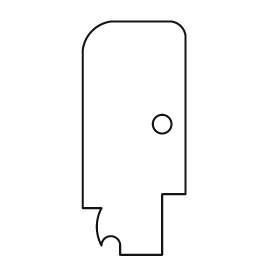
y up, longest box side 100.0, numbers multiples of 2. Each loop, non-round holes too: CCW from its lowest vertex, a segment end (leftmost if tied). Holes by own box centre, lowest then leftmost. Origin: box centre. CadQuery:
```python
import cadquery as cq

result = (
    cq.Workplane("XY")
    .moveTo(-6.0, -50.0)
    .lineTo(12.0, -50.0)
    .lineTo(12.0, -24.0)
    .lineTo(22.0, -24.0)
    .lineTo(22.0, 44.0)
    .threePointArc((20.0, 48.0), (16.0, 50.0))
    .lineTo(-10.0, 50.0)
    .threePointArc((-18.0, 46.0), (-22.0, 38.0))
    .lineTo(-22.0, -30.0)
    .lineTo(-14.0, -30.0)
    .threePointArc((-16.0, -38.0), (-14.0, -46.0))
    .threePointArc((-10.0, -42.0), (-6.0, -46.0))
    .close()
    .moveTo(12.0, 6.0)
    .circle(4.0)
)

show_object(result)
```